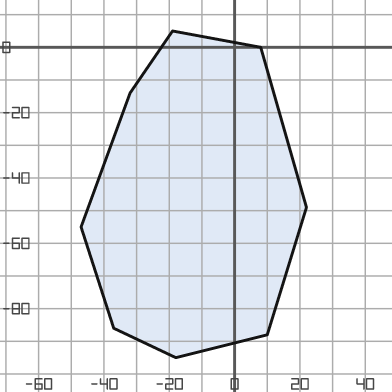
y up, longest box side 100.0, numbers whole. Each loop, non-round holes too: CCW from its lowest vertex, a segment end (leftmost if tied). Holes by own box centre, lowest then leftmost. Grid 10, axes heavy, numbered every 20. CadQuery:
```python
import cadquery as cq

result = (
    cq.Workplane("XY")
    .moveTo(-18.0, -95.0)
    .lineTo(10.0, -88.0)
    .lineTo(22.0, -49.0)
    .lineTo(8.0, 0.0)
    .lineTo(-19.0, 5.0)
    .lineTo(-32.0, -14.0)
    .lineTo(-47.0, -55.0)
    .lineTo(-37.0, -86.0)
    .close()
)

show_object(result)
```